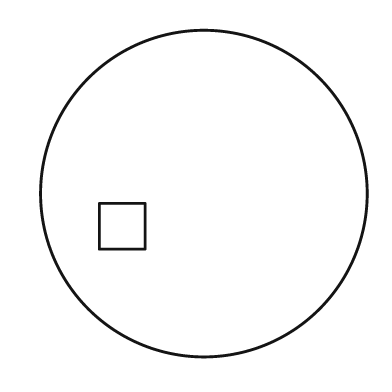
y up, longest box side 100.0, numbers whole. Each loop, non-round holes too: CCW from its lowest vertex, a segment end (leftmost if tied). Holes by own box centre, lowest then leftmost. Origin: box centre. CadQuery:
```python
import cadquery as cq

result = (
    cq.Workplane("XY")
    .moveTo(0.0, 0.0)
    .circle(50.0)
    .moveTo(-32.0, -17.0)
    .lineTo(-18.0, -17.0)
    .lineTo(-18.0, -3.0)
    .lineTo(-32.0, -3.0)
    .close()
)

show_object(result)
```